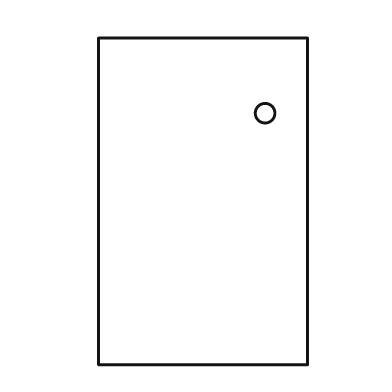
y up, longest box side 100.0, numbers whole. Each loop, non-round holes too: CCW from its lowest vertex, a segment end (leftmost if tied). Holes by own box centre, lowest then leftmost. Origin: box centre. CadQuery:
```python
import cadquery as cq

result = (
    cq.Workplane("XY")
    .moveTo(-32.0, -50.0)
    .lineTo(32.0, -50.0)
    .lineTo(32.0, 50.0)
    .lineTo(-32.0, 50.0)
    .close()
    .moveTo(19.0, 27.0)
    .circle(3.0)
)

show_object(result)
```